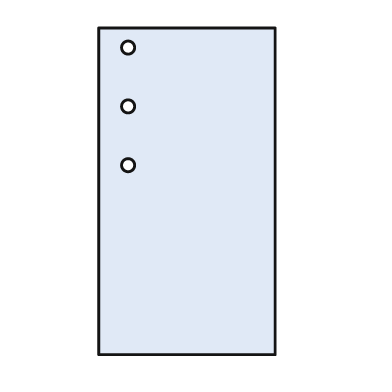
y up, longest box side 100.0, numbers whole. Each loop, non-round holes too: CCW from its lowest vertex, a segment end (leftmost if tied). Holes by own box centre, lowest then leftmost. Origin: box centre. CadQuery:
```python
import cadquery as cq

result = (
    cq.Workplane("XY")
    .moveTo(-27.0, -50.0)
    .lineTo(27.0, -50.0)
    .lineTo(27.0, 50.0)
    .lineTo(-27.0, 50.0)
    .close()
    .moveTo(-18.0, 8.0)
    .circle(2.0)
    .moveTo(-18.0, 26.0)
    .circle(2.0)
    .moveTo(-18.0, 44.0)
    .circle(2.0)
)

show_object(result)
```